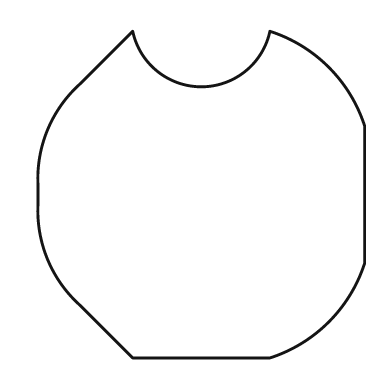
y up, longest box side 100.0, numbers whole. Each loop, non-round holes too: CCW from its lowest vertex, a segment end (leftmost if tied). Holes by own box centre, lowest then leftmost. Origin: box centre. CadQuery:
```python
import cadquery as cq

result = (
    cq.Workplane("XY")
    .moveTo(-21.0, -50.0)
    .lineTo(21.0, -50.0)
    .threePointArc((39.0, -39.0), (50.0, -21.0))
    .lineTo(50.0, 21.0)
    .threePointArc((39.0, 39.0), (21.0, 50.0))
    .threePointArc((0.0, 33.0), (-21.0, 50.0))
    .lineTo(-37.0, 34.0)
    .threePointArc((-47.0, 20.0), (-50.0, 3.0))
    .lineTo(-50.0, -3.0)
    .threePointArc((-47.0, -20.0), (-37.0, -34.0))
    .close()
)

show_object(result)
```